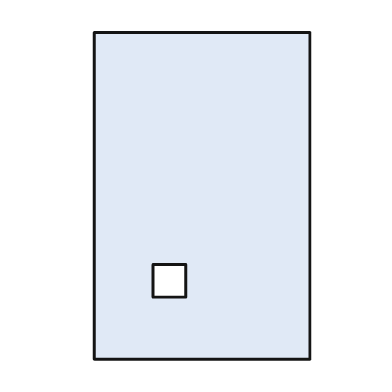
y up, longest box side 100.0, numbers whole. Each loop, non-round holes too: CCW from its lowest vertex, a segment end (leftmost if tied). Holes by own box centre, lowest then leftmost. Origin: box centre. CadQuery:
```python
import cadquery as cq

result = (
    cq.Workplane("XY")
    .moveTo(-33.0, -50.0)
    .lineTo(33.0, -50.0)
    .lineTo(33.0, 50.0)
    .lineTo(-33.0, 50.0)
    .close()
    .moveTo(-15.0, -31.0)
    .lineTo(-5.0, -31.0)
    .lineTo(-5.0, -21.0)
    .lineTo(-15.0, -21.0)
    .close()
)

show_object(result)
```